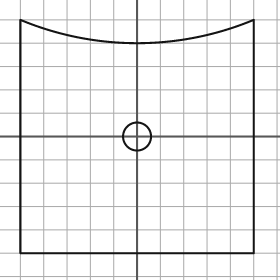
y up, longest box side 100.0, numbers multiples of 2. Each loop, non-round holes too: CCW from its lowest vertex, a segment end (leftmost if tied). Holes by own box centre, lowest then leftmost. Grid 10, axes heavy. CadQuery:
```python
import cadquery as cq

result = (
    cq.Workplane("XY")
    .moveTo(-50.0, -50.0)
    .lineTo(50.0, -50.0)
    .lineTo(50.0, 50.0)
    .threePointArc((0.0, 40.0), (-50.0, 50.0))
    .close()
    .moveTo(0.0, 0.0)
    .circle(6.0)
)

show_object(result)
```